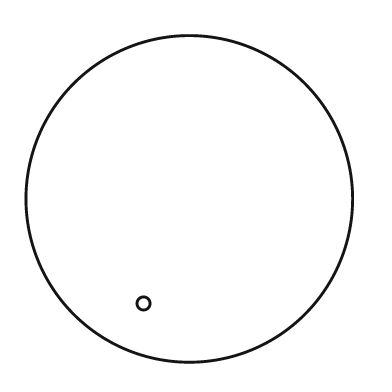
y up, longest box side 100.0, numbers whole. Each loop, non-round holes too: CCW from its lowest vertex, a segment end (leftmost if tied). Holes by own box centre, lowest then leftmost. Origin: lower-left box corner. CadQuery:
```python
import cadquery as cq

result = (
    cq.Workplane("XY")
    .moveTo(50.0, 50.0)
    .circle(50.0)
    .moveTo(36.0, 18.0)
    .circle(2.0)
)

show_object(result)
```